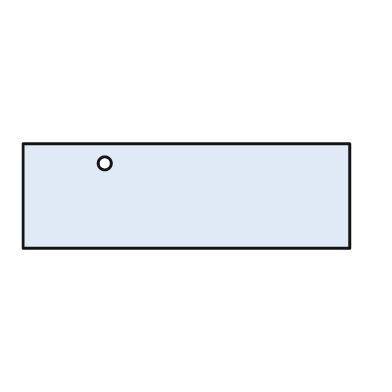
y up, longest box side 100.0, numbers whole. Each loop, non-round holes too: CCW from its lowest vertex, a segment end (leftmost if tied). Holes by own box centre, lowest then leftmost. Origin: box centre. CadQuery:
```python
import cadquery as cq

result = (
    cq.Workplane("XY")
    .moveTo(-50.0, -16.0)
    .lineTo(50.0, -16.0)
    .lineTo(50.0, 16.0)
    .lineTo(-50.0, 16.0)
    .close()
    .moveTo(-25.0, 10.0)
    .circle(2.0)
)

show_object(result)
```